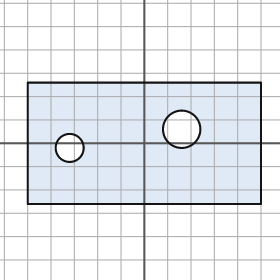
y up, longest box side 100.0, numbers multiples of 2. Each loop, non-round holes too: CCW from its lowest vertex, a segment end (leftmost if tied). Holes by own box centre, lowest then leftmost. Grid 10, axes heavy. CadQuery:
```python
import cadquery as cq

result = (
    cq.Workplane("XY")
    .moveTo(-50.0, -26.0)
    .lineTo(50.0, -26.0)
    .lineTo(50.0, 26.0)
    .lineTo(-50.0, 26.0)
    .close()
    .moveTo(-32.0, -2.0)
    .circle(6.0)
    .moveTo(16.0, 6.0)
    .circle(8.0)
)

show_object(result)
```